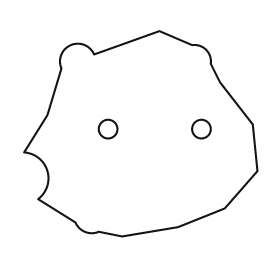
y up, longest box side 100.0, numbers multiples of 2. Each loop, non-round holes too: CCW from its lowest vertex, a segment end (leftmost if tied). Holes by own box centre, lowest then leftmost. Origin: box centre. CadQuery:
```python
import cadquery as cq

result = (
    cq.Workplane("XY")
    .moveTo(-8.0, -44.0)
    .lineTo(16.0, -40.0)
    .lineTo(36.0, -32.0)
    .lineTo(50.0, -16.0)
    .lineTo(48.0, 4.0)
    .lineTo(34.0, 22.0)
    .lineTo(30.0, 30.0)
    .threePointArc((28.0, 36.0), (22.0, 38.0))
    .lineTo(8.0, 44.0)
    .lineTo(-20.0, 34.0)
    .threePointArc((-30.0, 38.0), (-34.0, 28.0))
    .lineTo(-40.0, 8.0)
    .lineTo(-50.0, -8.0)
    .threePointArc((-40.0, -16.0), (-44.0, -28.0))
    .lineTo(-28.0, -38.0)
    .threePointArc((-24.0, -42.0), (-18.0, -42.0))
    .close()
    .moveTo(-14.0, 2.0)
    .circle(4.0)
    .moveTo(26.0, 2.0)
    .circle(4.0)
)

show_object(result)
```